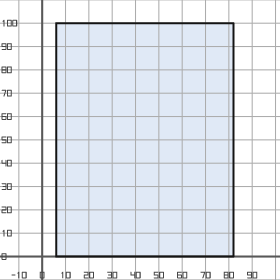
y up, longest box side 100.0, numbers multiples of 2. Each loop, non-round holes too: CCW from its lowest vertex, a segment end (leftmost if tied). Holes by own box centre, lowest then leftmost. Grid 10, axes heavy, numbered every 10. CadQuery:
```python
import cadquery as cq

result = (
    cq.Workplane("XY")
    .moveTo(6.0, 0.0)
    .lineTo(82.0, 0.0)
    .lineTo(82.0, 100.0)
    .lineTo(6.0, 100.0)
    .close()
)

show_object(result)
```